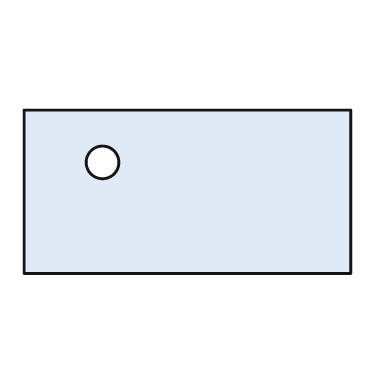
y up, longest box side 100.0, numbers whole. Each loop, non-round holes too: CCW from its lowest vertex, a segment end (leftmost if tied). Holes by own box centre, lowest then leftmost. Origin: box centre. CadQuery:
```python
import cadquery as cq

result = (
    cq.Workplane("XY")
    .moveTo(-50.0, -25.0)
    .lineTo(50.0, -25.0)
    .lineTo(50.0, 25.0)
    .lineTo(-50.0, 25.0)
    .close()
    .moveTo(-26.0, 9.0)
    .circle(5.0)
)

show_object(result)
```